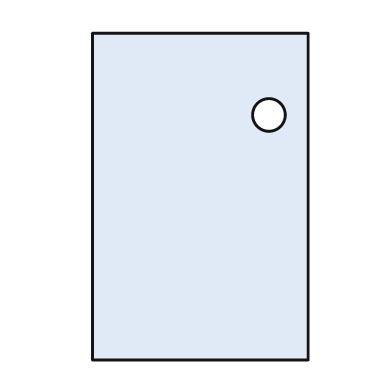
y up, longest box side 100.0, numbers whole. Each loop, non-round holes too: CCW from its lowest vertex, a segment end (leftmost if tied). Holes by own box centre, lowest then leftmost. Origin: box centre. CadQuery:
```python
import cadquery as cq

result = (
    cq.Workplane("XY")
    .moveTo(-33.0, -50.0)
    .lineTo(33.0, -50.0)
    .lineTo(33.0, 50.0)
    .lineTo(-33.0, 50.0)
    .close()
    .moveTo(21.0, 25.0)
    .circle(5.0)
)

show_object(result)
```